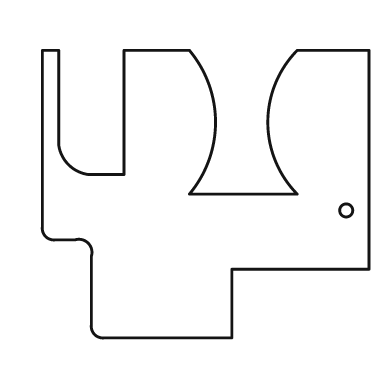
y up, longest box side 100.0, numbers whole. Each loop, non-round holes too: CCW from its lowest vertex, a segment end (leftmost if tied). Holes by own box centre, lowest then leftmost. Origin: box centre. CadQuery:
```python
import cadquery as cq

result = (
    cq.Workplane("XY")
    .moveTo(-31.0, -44.0)
    .lineTo(8.0, -44.0)
    .lineTo(8.0, -23.0)
    .lineTo(50.0, -23.0)
    .lineTo(50.0, 44.0)
    .lineTo(28.0, 44.0)
    .threePointArc((19.0, 22.0), (28.0, 0.0))
    .lineTo(-5.0, 0.0)
    .threePointArc((3.0, 22.0), (-5.0, 44.0))
    .lineTo(-25.0, 44.0)
    .lineTo(-25.0, 6.0)
    .lineTo(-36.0, 6.0)
    .threePointArc((-42.0, 9.0), (-45.0, 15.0))
    .lineTo(-45.0, 44.0)
    .lineTo(-50.0, 44.0)
    .lineTo(-50.0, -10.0)
    .threePointArc((-49.0, -13.0), (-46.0, -14.0))
    .lineTo(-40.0, -14.0)
    .threePointArc((-36.0, -15.0), (-35.0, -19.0))
    .lineTo(-35.0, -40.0)
    .threePointArc((-34.0, -43.0), (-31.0, -44.0))
    .close()
    .moveTo(43.0, -5.0)
    .circle(2.0)
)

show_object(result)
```